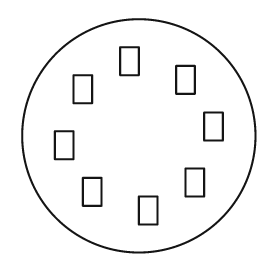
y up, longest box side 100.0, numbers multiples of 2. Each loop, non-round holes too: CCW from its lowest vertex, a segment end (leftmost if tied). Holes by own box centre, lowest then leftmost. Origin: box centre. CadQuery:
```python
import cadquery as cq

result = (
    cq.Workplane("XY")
    .moveTo(0.0, 0.0)
    .circle(50.0)
    .moveTo(0.0, -38.0)
    .lineTo(8.0, -38.0)
    .lineTo(8.0, -26.0)
    .lineTo(0.0, -26.0)
    .close()
    .moveTo(-24.0, -30.0)
    .lineTo(-16.0, -30.0)
    .lineTo(-16.0, -18.0)
    .lineTo(-24.0, -18.0)
    .close()
    .moveTo(20.0, -26.0)
    .lineTo(28.0, -26.0)
    .lineTo(28.0, -14.0)
    .lineTo(20.0, -14.0)
    .close()
    .moveTo(-36.0, -10.0)
    .lineTo(-28.0, -10.0)
    .lineTo(-28.0, 2.0)
    .lineTo(-36.0, 2.0)
    .close()
    .moveTo(28.0, -2.0)
    .lineTo(36.0, -2.0)
    .lineTo(36.0, 10.0)
    .lineTo(28.0, 10.0)
    .close()
    .moveTo(-28.0, 14.0)
    .lineTo(-20.0, 14.0)
    .lineTo(-20.0, 26.0)
    .lineTo(-28.0, 26.0)
    .close()
    .moveTo(16.0, 18.0)
    .lineTo(24.0, 18.0)
    .lineTo(24.0, 30.0)
    .lineTo(16.0, 30.0)
    .close()
    .moveTo(-8.0, 26.0)
    .lineTo(0.0, 26.0)
    .lineTo(0.0, 38.0)
    .lineTo(-8.0, 38.0)
    .close()
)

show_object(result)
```